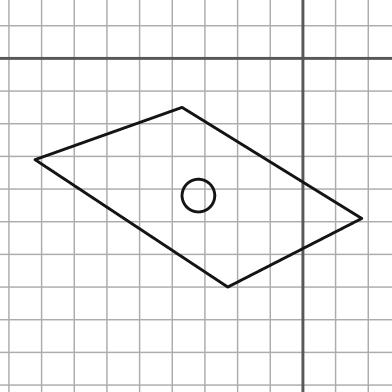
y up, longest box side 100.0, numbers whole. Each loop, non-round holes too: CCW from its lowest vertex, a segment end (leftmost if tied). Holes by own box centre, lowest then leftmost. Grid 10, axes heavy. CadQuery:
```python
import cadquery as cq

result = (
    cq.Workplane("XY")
    .moveTo(-23.0, -70.0)
    .lineTo(18.0, -49.0)
    .lineTo(-37.0, -15.0)
    .lineTo(-82.0, -31.0)
    .close()
    .moveTo(-32.0, -42.0)
    .circle(5.0)
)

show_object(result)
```